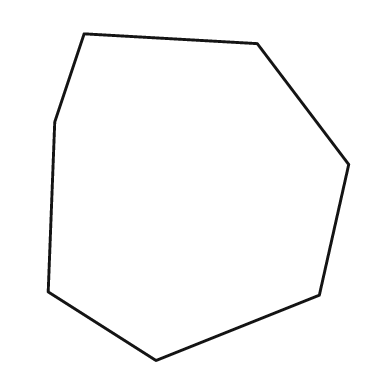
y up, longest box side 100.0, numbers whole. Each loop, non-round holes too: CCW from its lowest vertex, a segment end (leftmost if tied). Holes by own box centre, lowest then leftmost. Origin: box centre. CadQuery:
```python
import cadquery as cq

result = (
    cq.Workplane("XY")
    .moveTo(-13.0, -50.0)
    .lineTo(37.0, -30.0)
    .lineTo(46.0, 10.0)
    .lineTo(18.0, 47.0)
    .lineTo(-35.0, 50.0)
    .lineTo(-44.0, 23.0)
    .lineTo(-46.0, -29.0)
    .close()
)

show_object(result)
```